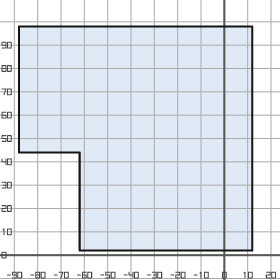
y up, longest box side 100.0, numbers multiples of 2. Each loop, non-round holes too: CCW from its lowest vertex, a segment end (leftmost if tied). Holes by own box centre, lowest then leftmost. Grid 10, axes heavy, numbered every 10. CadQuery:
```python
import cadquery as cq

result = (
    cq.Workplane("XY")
    .moveTo(-62.0, 2.0)
    .lineTo(12.0, 2.0)
    .lineTo(12.0, 98.0)
    .lineTo(-88.0, 98.0)
    .lineTo(-88.0, 44.0)
    .lineTo(-62.0, 44.0)
    .close()
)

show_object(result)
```